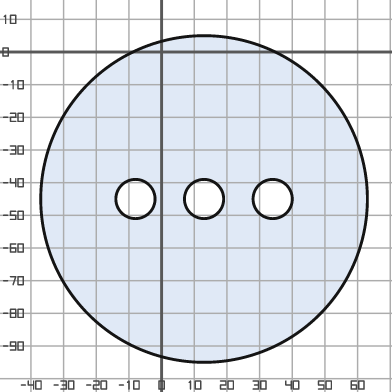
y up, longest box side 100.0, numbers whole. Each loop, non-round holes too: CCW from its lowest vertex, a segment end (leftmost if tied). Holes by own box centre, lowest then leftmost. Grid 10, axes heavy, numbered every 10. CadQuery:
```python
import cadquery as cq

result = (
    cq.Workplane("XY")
    .moveTo(13.0, -45.0)
    .circle(50.0)
    .moveTo(-8.0, -45.0)
    .circle(6.0)
    .moveTo(13.0, -45.0)
    .circle(6.0)
    .moveTo(34.0, -45.0)
    .circle(6.0)
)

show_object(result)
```